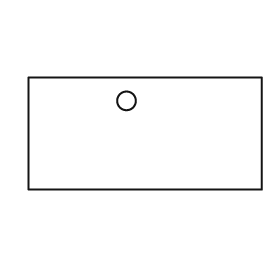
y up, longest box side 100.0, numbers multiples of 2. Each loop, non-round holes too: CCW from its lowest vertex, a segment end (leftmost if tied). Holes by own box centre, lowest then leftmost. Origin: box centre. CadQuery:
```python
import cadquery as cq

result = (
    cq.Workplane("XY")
    .moveTo(-50.0, -24.0)
    .lineTo(50.0, -24.0)
    .lineTo(50.0, 24.0)
    .lineTo(-50.0, 24.0)
    .close()
    .moveTo(-8.0, 14.0)
    .circle(4.0)
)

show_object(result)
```